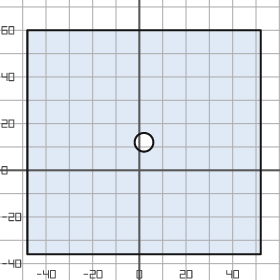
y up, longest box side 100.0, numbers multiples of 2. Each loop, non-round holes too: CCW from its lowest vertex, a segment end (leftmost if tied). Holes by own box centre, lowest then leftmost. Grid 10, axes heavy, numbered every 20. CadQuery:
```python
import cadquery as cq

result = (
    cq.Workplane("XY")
    .moveTo(-48.0, -36.0)
    .lineTo(52.0, -36.0)
    .lineTo(52.0, 60.0)
    .lineTo(-48.0, 60.0)
    .close()
    .moveTo(2.0, 12.0)
    .circle(4.0)
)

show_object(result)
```